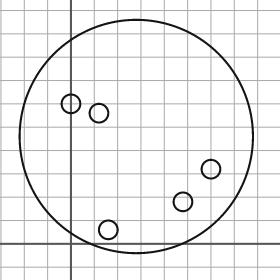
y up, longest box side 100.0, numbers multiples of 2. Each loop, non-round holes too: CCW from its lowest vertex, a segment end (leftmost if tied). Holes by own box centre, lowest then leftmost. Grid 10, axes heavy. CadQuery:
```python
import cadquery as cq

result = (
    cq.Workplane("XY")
    .moveTo(28.0, 46.0)
    .circle(50.0)
    .moveTo(16.0, 6.0)
    .circle(4.0)
    .moveTo(48.0, 18.0)
    .circle(4.0)
    .moveTo(60.0, 32.0)
    .circle(4.0)
    .moveTo(12.0, 56.0)
    .circle(4.0)
    .moveTo(0.0, 60.0)
    .circle(4.0)
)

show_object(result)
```